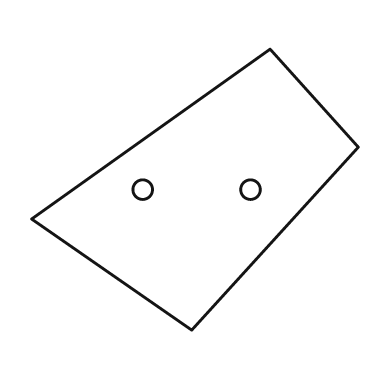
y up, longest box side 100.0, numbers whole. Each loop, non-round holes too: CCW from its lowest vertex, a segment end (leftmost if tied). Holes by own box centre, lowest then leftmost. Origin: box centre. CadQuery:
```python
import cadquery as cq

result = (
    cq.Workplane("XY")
    .moveTo(-1.0, -43.0)
    .lineTo(50.0, 13.0)
    .lineTo(23.0, 43.0)
    .lineTo(-50.0, -9.0)
    .close()
    .moveTo(-16.0, 0.0)
    .circle(3.0)
    .moveTo(17.0, 0.0)
    .circle(3.0)
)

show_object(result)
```